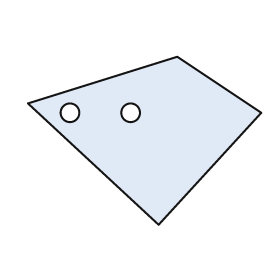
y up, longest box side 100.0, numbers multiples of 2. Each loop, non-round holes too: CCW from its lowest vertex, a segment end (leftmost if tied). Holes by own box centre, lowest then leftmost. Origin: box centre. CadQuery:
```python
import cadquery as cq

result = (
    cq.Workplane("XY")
    .moveTo(6.0, -36.0)
    .lineTo(50.0, 12.0)
    .lineTo(14.0, 36.0)
    .lineTo(-50.0, 16.0)
    .close()
    .moveTo(-32.0, 12.0)
    .circle(4.0)
    .moveTo(-6.0, 12.0)
    .circle(4.0)
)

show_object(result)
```